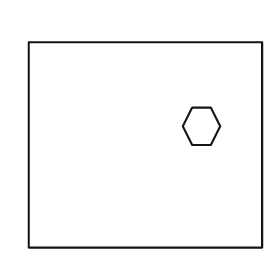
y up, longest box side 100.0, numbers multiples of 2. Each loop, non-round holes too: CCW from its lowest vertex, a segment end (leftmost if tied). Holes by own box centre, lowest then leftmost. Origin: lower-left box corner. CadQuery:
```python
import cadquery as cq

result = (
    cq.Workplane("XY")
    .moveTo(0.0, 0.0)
    .lineTo(100.0, 0.0)
    .lineTo(100.0, 88.0)
    .lineTo(0.0, 88.0)
    .close()
    .moveTo(70.0, 44.0)
    .lineTo(78.0, 44.0)
    .lineTo(82.0, 52.0)
    .lineTo(78.0, 60.0)
    .lineTo(70.0, 60.0)
    .lineTo(66.0, 52.0)
    .close()
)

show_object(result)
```